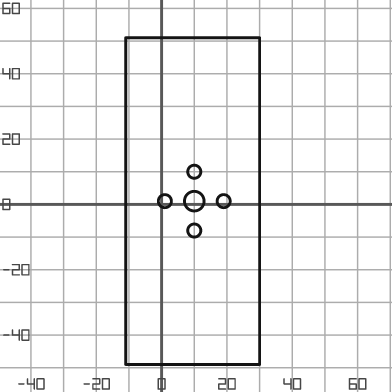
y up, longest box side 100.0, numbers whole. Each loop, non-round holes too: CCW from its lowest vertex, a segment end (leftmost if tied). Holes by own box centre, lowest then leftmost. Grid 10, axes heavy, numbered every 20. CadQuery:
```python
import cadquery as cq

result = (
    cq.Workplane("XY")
    .moveTo(-11.0, -49.0)
    .lineTo(30.0, -49.0)
    .lineTo(30.0, 51.0)
    .lineTo(-11.0, 51.0)
    .close()
    .moveTo(10.0, -8.0)
    .circle(2.0)
    .moveTo(1.0, 1.0)
    .circle(2.0)
    .moveTo(10.0, 1.0)
    .circle(3.0)
    .moveTo(19.0, 1.0)
    .circle(2.0)
    .moveTo(10.0, 10.0)
    .circle(2.0)
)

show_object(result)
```